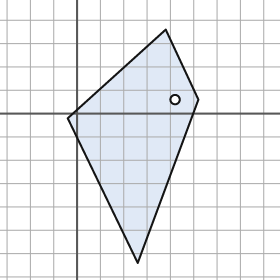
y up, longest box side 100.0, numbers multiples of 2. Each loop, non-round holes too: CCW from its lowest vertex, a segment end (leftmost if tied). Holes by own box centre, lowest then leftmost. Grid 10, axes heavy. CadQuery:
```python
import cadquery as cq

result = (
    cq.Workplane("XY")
    .moveTo(26.0, -64.0)
    .lineTo(52.0, 6.0)
    .lineTo(38.0, 36.0)
    .lineTo(-4.0, -2.0)
    .close()
    .moveTo(42.0, 6.0)
    .circle(2.0)
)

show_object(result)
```